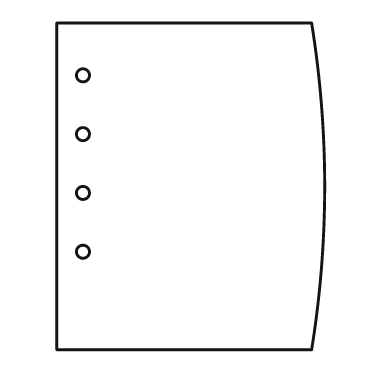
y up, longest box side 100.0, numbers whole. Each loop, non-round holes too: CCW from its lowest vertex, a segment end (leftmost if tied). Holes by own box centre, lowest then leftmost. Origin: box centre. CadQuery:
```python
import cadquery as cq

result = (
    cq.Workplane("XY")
    .moveTo(-41.0, -50.0)
    .lineTo(37.0, -50.0)
    .threePointArc((41.0, 0.0), (37.0, 50.0))
    .lineTo(-41.0, 50.0)
    .close()
    .moveTo(-33.0, -20.0)
    .circle(2.0)
    .moveTo(-33.0, -2.0)
    .circle(2.0)
    .moveTo(-33.0, 16.0)
    .circle(2.0)
    .moveTo(-33.0, 34.0)
    .circle(2.0)
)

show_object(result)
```